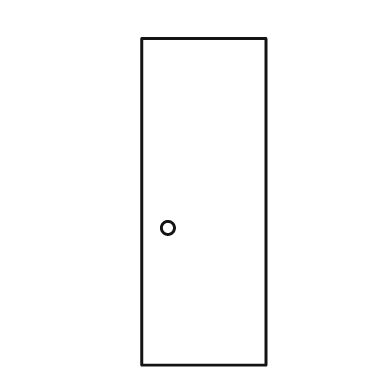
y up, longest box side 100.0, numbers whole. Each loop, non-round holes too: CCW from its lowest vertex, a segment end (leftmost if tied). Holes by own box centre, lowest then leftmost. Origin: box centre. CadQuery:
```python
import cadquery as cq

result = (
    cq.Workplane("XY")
    .moveTo(-19.0, -50.0)
    .lineTo(19.0, -50.0)
    .lineTo(19.0, 50.0)
    .lineTo(-19.0, 50.0)
    .close()
    .moveTo(-11.0, -8.0)
    .circle(2.0)
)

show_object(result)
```